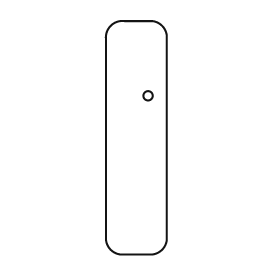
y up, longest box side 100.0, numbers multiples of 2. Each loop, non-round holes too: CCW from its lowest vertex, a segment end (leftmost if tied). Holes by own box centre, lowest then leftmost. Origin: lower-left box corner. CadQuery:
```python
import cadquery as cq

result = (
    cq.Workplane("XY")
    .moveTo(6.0, 0.0)
    .lineTo(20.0, 0.0)
    .threePointArc((24.0, 2.0), (26.0, 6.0))
    .lineTo(26.0, 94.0)
    .threePointArc((24.0, 98.0), (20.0, 100.0))
    .lineTo(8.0, 100.0)
    .threePointArc((2.0, 98.0), (0.0, 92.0))
    .lineTo(0.0, 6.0)
    .threePointArc((2.0, 2.0), (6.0, 0.0))
    .close()
    .moveTo(18.0, 68.0)
    .circle(2.0)
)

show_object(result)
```